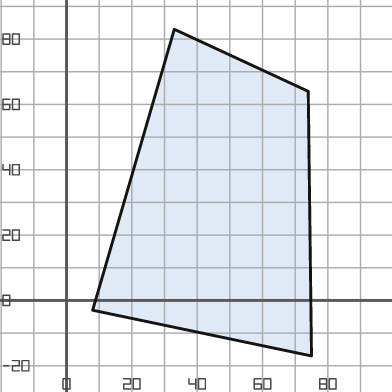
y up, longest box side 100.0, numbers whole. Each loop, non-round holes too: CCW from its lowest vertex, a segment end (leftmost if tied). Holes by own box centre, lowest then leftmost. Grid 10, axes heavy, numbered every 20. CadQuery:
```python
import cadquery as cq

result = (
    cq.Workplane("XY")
    .moveTo(75.0, -17.0)
    .lineTo(74.0, 64.0)
    .lineTo(33.0, 83.0)
    .lineTo(8.0, -3.0)
    .close()
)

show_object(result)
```